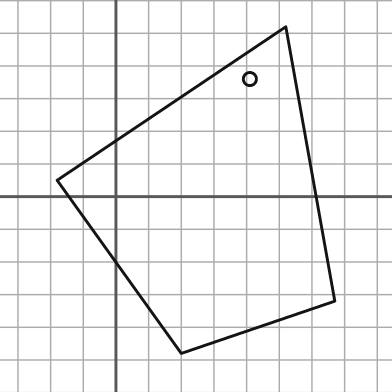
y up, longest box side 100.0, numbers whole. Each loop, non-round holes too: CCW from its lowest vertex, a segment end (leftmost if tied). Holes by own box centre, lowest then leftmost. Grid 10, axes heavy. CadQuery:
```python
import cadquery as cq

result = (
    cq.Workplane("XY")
    .moveTo(20.0, -48.0)
    .lineTo(67.0, -32.0)
    .lineTo(52.0, 52.0)
    .lineTo(-18.0, 5.0)
    .close()
    .moveTo(41.0, 36.0)
    .circle(2.0)
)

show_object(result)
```